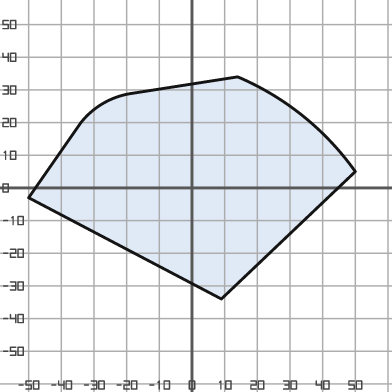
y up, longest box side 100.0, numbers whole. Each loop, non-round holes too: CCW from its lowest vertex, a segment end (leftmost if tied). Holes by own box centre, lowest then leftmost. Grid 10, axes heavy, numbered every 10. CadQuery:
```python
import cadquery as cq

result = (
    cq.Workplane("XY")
    .moveTo(9.0, -34.0)
    .lineTo(50.0, 5.0)
    .threePointArc((34.0, 22.0), (14.0, 34.0))
    .lineTo(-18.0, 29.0)
    .threePointArc((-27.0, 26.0), (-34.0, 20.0))
    .lineTo(-50.0, -3.0)
    .close()
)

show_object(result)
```